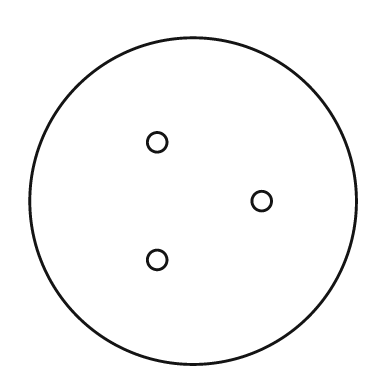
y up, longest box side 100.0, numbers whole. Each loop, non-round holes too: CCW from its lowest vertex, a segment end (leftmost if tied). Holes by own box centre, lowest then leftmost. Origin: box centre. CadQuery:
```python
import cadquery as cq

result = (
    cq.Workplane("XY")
    .moveTo(0.0, 0.0)
    .circle(50.0)
    .moveTo(-11.0, -18.0)
    .circle(3.0)
    .moveTo(21.0, 0.0)
    .circle(3.0)
    .moveTo(-11.0, 18.0)
    .circle(3.0)
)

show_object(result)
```